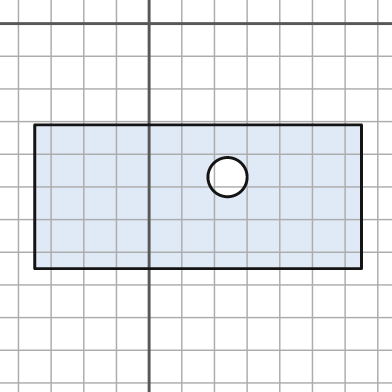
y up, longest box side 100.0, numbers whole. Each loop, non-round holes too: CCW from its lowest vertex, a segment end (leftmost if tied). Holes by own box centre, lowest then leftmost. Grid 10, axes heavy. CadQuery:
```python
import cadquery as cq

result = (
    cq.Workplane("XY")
    .moveTo(-35.0, -75.0)
    .lineTo(65.0, -75.0)
    .lineTo(65.0, -31.0)
    .lineTo(-35.0, -31.0)
    .close()
    .moveTo(24.0, -47.0)
    .circle(6.0)
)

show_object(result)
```